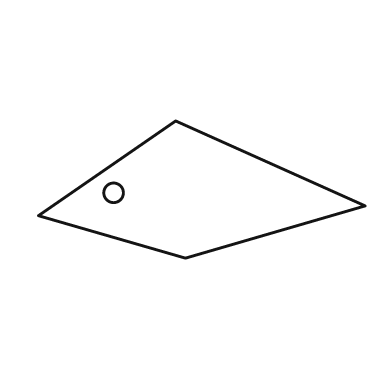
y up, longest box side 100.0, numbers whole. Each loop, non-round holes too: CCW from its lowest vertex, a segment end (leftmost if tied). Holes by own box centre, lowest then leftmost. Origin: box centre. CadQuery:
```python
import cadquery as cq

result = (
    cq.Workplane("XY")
    .moveTo(-5.0, -21.0)
    .lineTo(50.0, -5.0)
    .lineTo(-8.0, 21.0)
    .lineTo(-50.0, -8.0)
    .close()
    .moveTo(-27.0, -1.0)
    .circle(3.0)
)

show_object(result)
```